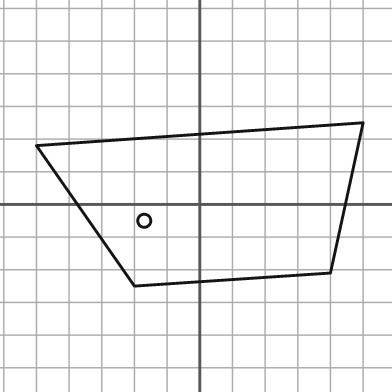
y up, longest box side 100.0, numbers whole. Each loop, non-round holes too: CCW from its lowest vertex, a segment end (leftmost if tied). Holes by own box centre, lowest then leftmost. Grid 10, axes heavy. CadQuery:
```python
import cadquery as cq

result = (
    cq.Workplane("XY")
    .moveTo(-20.0, -25.0)
    .lineTo(40.0, -21.0)
    .lineTo(50.0, 25.0)
    .lineTo(-50.0, 18.0)
    .close()
    .moveTo(-17.0, -5.0)
    .circle(2.0)
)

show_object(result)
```